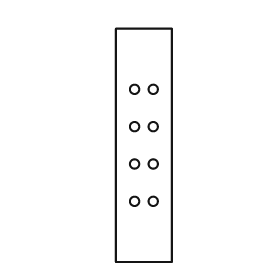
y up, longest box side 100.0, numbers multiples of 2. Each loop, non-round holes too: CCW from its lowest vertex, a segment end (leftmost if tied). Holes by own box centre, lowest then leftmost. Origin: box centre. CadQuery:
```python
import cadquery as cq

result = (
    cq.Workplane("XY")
    .moveTo(-12.0, -50.0)
    .lineTo(12.0, -50.0)
    .lineTo(12.0, 50.0)
    .lineTo(-12.0, 50.0)
    .close()
    .moveTo(-4.0, -24.0)
    .circle(2.0)
    .moveTo(4.0, -24.0)
    .circle(2.0)
    .moveTo(-4.0, -8.0)
    .circle(2.0)
    .moveTo(4.0, -8.0)
    .circle(2.0)
    .moveTo(-4.0, 8.0)
    .circle(2.0)
    .moveTo(4.0, 8.0)
    .circle(2.0)
    .moveTo(-4.0, 24.0)
    .circle(2.0)
    .moveTo(4.0, 24.0)
    .circle(2.0)
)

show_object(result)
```